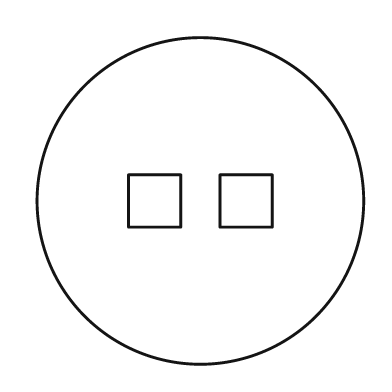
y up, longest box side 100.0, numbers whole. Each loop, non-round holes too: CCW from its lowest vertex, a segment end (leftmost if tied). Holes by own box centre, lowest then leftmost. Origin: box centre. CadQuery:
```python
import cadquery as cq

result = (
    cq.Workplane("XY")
    .moveTo(0.0, 0.0)
    .circle(50.0)
    .moveTo(-22.0, -8.0)
    .lineTo(-6.0, -8.0)
    .lineTo(-6.0, 8.0)
    .lineTo(-22.0, 8.0)
    .close()
    .moveTo(6.0, -8.0)
    .lineTo(22.0, -8.0)
    .lineTo(22.0, 8.0)
    .lineTo(6.0, 8.0)
    .close()
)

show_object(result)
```